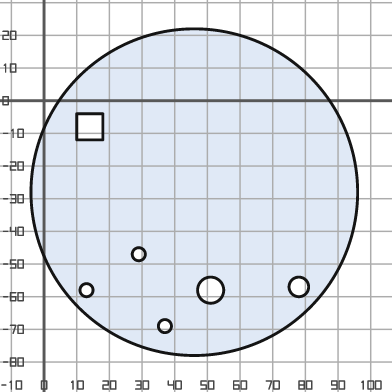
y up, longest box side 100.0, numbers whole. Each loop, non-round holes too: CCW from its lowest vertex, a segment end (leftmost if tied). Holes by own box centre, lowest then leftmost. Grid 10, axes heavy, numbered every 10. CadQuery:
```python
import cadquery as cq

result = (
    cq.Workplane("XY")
    .moveTo(46.0, -28.0)
    .circle(50.0)
    .moveTo(37.0, -69.0)
    .circle(2.0)
    .moveTo(13.0, -58.0)
    .circle(2.0)
    .moveTo(51.0, -58.0)
    .circle(4.0)
    .moveTo(78.0, -57.0)
    .circle(3.0)
    .moveTo(29.0, -47.0)
    .circle(2.0)
    .moveTo(10.0, -12.0)
    .lineTo(18.0, -12.0)
    .lineTo(18.0, -4.0)
    .lineTo(10.0, -4.0)
    .close()
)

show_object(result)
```